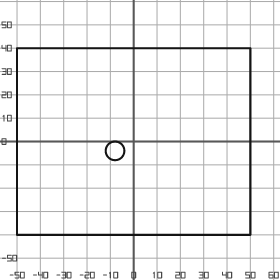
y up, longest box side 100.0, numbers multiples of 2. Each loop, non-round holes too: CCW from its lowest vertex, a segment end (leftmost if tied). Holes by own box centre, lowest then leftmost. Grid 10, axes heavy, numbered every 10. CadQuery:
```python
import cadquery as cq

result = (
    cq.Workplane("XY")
    .moveTo(-50.0, -40.0)
    .lineTo(50.0, -40.0)
    .lineTo(50.0, 40.0)
    .lineTo(-50.0, 40.0)
    .close()
    .moveTo(-8.0, -4.0)
    .circle(4.0)
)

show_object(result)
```